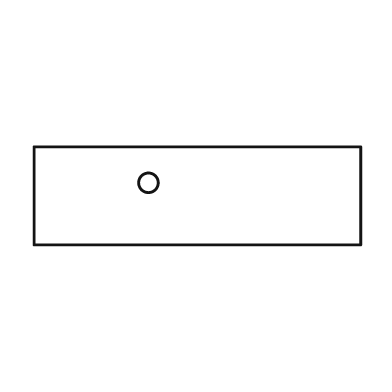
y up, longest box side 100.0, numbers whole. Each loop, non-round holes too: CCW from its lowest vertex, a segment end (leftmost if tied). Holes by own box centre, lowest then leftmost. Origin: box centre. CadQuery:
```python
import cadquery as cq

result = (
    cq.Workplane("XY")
    .moveTo(-50.0, -15.0)
    .lineTo(50.0, -15.0)
    .lineTo(50.0, 15.0)
    .lineTo(-50.0, 15.0)
    .close()
    .moveTo(-15.0, 4.0)
    .circle(3.0)
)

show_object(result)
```